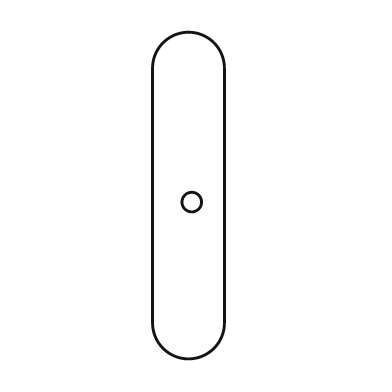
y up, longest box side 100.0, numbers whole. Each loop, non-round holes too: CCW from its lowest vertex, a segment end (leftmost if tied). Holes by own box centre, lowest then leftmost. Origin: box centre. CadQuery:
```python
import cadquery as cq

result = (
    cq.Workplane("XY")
    .moveTo(-11.0, -39.0)
    .threePointArc((0.0, -50.0), (11.0, -39.0))
    .lineTo(11.0, 39.0)
    .threePointArc((0.0, 50.0), (-11.0, 39.0))
    .close()
    .moveTo(1.0, -2.0)
    .circle(3.0)
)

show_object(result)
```